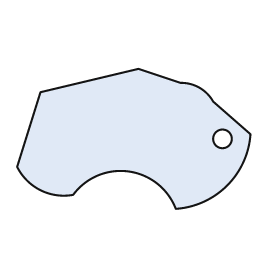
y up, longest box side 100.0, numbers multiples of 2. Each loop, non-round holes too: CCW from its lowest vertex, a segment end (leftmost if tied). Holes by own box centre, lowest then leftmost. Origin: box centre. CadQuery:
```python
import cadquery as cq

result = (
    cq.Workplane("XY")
    .moveTo(18.0, -30.0)
    .threePointArc((40.0, -20.0), (50.0, 2.0))
    .lineTo(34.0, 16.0)
    .threePointArc((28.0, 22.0), (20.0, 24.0))
    .lineTo(2.0, 30.0)
    .lineTo(-40.0, 20.0)
    .lineTo(-50.0, -12.0)
    .threePointArc((-40.0, -22.0), (-26.0, -24.0))
    .threePointArc((-2.0, -14.0), (18.0, -30.0))
    .close()
    .moveTo(38.0, 0.0)
    .circle(4.0)
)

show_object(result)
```